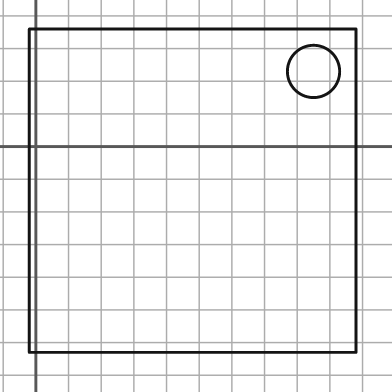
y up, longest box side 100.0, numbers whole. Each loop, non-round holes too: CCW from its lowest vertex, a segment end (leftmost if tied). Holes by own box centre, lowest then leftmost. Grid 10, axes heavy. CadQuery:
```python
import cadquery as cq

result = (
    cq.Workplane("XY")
    .moveTo(-2.0, -63.0)
    .lineTo(98.0, -63.0)
    .lineTo(98.0, 36.0)
    .lineTo(-2.0, 36.0)
    .close()
    .moveTo(85.0, 23.0)
    .circle(8.0)
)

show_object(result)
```